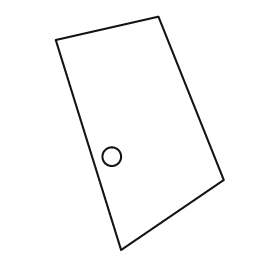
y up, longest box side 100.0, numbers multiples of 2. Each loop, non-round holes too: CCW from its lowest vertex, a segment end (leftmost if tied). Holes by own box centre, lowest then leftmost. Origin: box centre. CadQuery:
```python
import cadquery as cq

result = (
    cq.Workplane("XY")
    .moveTo(-8.0, -50.0)
    .lineTo(36.0, -20.0)
    .lineTo(8.0, 50.0)
    .lineTo(-36.0, 40.0)
    .close()
    .moveTo(-12.0, -10.0)
    .circle(4.0)
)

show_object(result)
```